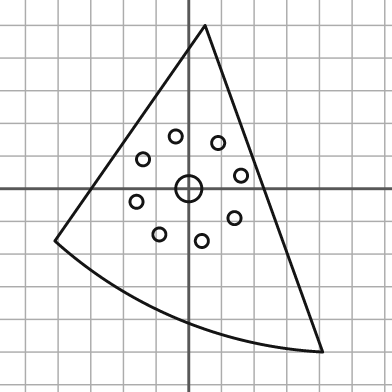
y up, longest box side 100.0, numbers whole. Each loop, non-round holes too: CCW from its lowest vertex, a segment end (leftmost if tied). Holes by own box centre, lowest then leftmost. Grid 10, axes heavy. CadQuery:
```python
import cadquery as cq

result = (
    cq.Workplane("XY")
    .moveTo(41.0, -50.0)
    .lineTo(5.0, 50.0)
    .lineTo(-41.0, -16.0)
    .threePointArc((-3.0, -40.0), (41.0, -50.0))
    .close()
    .moveTo(4.0, -16.0)
    .circle(2.0)
    .moveTo(-9.0, -14.0)
    .circle(2.0)
    .moveTo(14.0, -9.0)
    .circle(2.0)
    .moveTo(-16.0, -4.0)
    .circle(2.0)
    .moveTo(0.0, 0.0)
    .circle(4.0)
    .moveTo(16.0, 4.0)
    .circle(2.0)
    .moveTo(-14.0, 9.0)
    .circle(2.0)
    .moveTo(9.0, 14.0)
    .circle(2.0)
    .moveTo(-4.0, 16.0)
    .circle(2.0)
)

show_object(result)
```